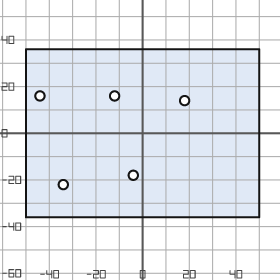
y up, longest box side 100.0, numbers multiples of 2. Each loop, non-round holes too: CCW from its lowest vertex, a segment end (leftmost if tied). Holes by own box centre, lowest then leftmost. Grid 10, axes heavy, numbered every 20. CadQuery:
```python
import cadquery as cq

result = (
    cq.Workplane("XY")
    .moveTo(-50.0, -36.0)
    .lineTo(50.0, -36.0)
    .lineTo(50.0, 36.0)
    .lineTo(-50.0, 36.0)
    .close()
    .moveTo(-34.0, -22.0)
    .circle(2.0)
    .moveTo(-4.0, -18.0)
    .circle(2.0)
    .moveTo(18.0, 14.0)
    .circle(2.0)
    .moveTo(-44.0, 16.0)
    .circle(2.0)
    .moveTo(-12.0, 16.0)
    .circle(2.0)
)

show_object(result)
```